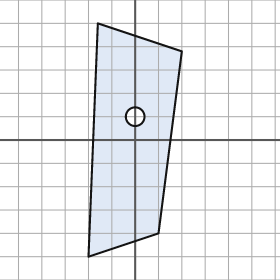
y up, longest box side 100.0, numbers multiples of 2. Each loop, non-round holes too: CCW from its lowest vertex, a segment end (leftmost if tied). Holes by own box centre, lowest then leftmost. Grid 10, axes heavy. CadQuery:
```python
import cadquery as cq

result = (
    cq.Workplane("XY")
    .moveTo(-20.0, -50.0)
    .lineTo(10.0, -40.0)
    .lineTo(20.0, 38.0)
    .lineTo(-16.0, 50.0)
    .close()
    .moveTo(0.0, 10.0)
    .circle(4.0)
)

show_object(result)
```